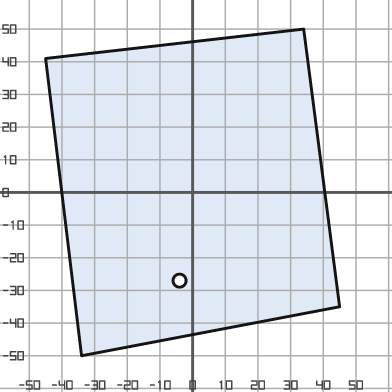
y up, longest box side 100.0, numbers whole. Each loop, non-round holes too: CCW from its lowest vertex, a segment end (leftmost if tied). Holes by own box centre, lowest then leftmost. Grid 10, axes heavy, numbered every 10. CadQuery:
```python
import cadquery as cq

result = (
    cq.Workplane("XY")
    .moveTo(-34.0, -50.0)
    .lineTo(45.0, -35.0)
    .lineTo(34.0, 50.0)
    .lineTo(-45.0, 41.0)
    .close()
    .moveTo(-4.0, -27.0)
    .circle(2.0)
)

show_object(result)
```